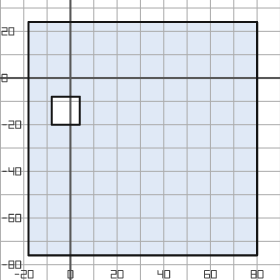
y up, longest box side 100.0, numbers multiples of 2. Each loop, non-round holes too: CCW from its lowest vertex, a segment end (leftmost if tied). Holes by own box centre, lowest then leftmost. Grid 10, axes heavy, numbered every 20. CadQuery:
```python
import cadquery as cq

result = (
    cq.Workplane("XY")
    .moveTo(-18.0, -76.0)
    .lineTo(80.0, -76.0)
    .lineTo(80.0, 24.0)
    .lineTo(-18.0, 24.0)
    .close()
    .moveTo(-8.0, -20.0)
    .lineTo(4.0, -20.0)
    .lineTo(4.0, -8.0)
    .lineTo(-8.0, -8.0)
    .close()
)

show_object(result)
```